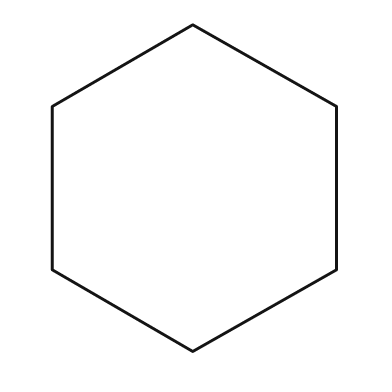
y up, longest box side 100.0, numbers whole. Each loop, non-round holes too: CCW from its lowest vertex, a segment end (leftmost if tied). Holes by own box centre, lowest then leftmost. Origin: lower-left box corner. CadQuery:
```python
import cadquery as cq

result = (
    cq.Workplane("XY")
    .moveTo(43.0, 0.0)
    .lineTo(87.0, 25.0)
    .lineTo(87.0, 75.0)
    .lineTo(43.0, 100.0)
    .lineTo(0.0, 75.0)
    .lineTo(0.0, 25.0)
    .close()
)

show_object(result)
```